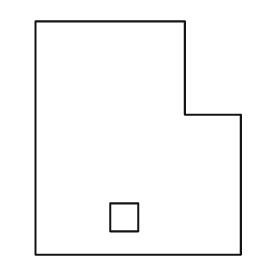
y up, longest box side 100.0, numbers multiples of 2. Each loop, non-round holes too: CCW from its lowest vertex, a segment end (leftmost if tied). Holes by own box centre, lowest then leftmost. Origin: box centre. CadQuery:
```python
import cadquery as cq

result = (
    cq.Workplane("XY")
    .moveTo(-44.0, -50.0)
    .lineTo(44.0, -50.0)
    .lineTo(44.0, 10.0)
    .lineTo(20.0, 10.0)
    .lineTo(20.0, 50.0)
    .lineTo(-44.0, 50.0)
    .close()
    .moveTo(-12.0, -40.0)
    .lineTo(0.0, -40.0)
    .lineTo(0.0, -28.0)
    .lineTo(-12.0, -28.0)
    .close()
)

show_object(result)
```